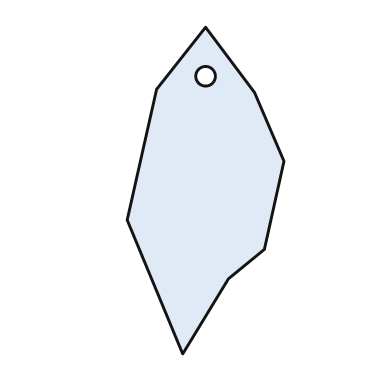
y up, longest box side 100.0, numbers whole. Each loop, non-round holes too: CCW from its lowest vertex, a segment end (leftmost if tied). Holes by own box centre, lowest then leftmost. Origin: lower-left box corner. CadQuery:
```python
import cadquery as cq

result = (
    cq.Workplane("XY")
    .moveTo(17.0, 0.0)
    .lineTo(31.0, 23.0)
    .lineTo(42.0, 32.0)
    .lineTo(48.0, 59.0)
    .lineTo(39.0, 80.0)
    .lineTo(24.0, 100.0)
    .lineTo(9.0, 81.0)
    .lineTo(0.0, 41.0)
    .close()
    .moveTo(24.0, 85.0)
    .circle(3.0)
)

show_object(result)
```